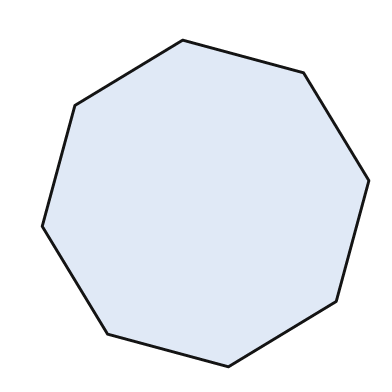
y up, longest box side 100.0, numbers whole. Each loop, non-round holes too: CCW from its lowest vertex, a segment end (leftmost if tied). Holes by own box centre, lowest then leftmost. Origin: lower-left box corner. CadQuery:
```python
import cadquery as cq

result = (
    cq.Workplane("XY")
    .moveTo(57.0, 0.0)
    .lineTo(90.0, 20.0)
    .lineTo(100.0, 57.0)
    .lineTo(80.0, 90.0)
    .lineTo(43.0, 100.0)
    .lineTo(10.0, 80.0)
    .lineTo(0.0, 43.0)
    .lineTo(20.0, 10.0)
    .close()
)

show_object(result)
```